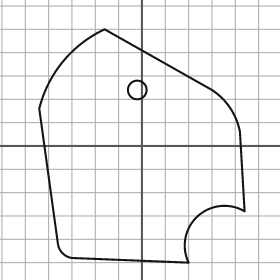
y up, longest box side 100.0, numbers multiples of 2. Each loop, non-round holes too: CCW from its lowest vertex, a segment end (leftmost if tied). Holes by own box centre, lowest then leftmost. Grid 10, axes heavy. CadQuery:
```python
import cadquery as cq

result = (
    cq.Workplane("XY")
    .moveTo(20.0, -50.0)
    .threePointArc((24.0, -30.0), (44.0, -28.0))
    .lineTo(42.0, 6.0)
    .threePointArc((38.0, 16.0), (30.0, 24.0))
    .lineTo(-16.0, 50.0)
    .threePointArc((-34.0, 36.0), (-44.0, 16.0))
    .lineTo(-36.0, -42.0)
    .threePointArc((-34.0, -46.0), (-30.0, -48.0))
    .close()
    .moveTo(-2.0, 24.0)
    .circle(4.0)
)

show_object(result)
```